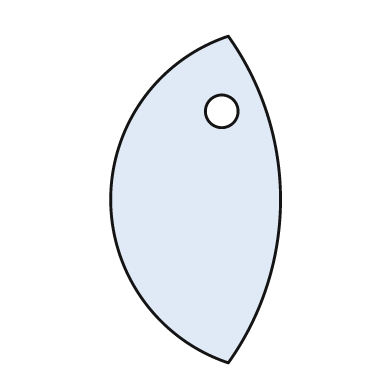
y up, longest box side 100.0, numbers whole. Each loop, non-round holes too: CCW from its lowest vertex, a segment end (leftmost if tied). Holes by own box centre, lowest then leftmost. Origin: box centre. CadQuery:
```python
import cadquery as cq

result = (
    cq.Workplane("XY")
    .moveTo(10.0, -50.0)
    .threePointArc((26.0, 0.0), (10.0, 50.0))
    .threePointArc((-26.0, 0.0), (10.0, -50.0))
    .close()
    .moveTo(8.0, 27.0)
    .circle(5.0)
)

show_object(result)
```